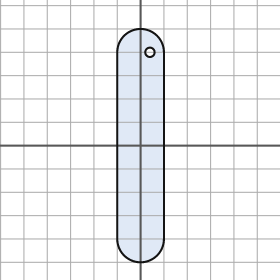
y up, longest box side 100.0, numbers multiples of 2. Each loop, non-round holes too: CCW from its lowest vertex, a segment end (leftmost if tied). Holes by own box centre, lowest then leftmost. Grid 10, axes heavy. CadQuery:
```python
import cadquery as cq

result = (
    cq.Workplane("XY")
    .moveTo(-10.0, -40.0)
    .threePointArc((0.0, -50.0), (10.0, -40.0))
    .lineTo(10.0, 40.0)
    .threePointArc((0.0, 50.0), (-10.0, 40.0))
    .close()
    .moveTo(4.0, 40.0)
    .circle(2.0)
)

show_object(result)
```